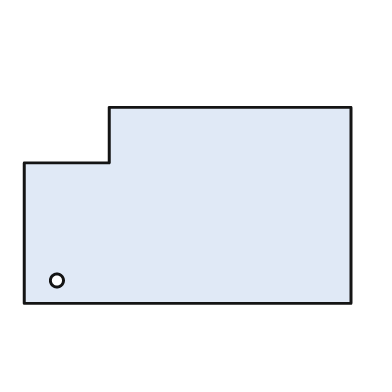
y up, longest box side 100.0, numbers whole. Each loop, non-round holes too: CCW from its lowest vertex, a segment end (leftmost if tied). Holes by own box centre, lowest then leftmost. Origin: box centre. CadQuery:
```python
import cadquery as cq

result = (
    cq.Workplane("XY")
    .moveTo(-50.0, -30.0)
    .lineTo(50.0, -30.0)
    .lineTo(50.0, 30.0)
    .lineTo(-24.0, 30.0)
    .lineTo(-24.0, 13.0)
    .lineTo(-50.0, 13.0)
    .close()
    .moveTo(-40.0, -23.0)
    .circle(2.0)
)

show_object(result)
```